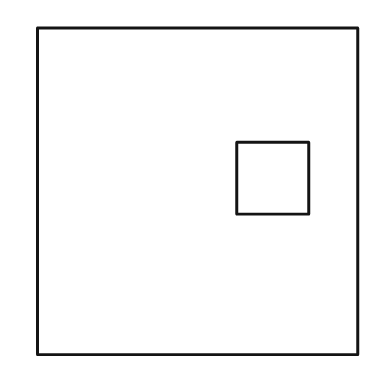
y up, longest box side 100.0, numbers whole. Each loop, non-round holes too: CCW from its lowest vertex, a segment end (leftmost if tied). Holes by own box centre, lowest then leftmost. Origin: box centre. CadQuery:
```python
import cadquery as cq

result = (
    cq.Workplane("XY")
    .moveTo(-49.0, -50.0)
    .lineTo(49.0, -50.0)
    .lineTo(49.0, 50.0)
    .lineTo(-49.0, 50.0)
    .close()
    .moveTo(12.0, -7.0)
    .lineTo(34.0, -7.0)
    .lineTo(34.0, 15.0)
    .lineTo(12.0, 15.0)
    .close()
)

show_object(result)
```